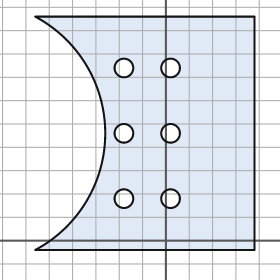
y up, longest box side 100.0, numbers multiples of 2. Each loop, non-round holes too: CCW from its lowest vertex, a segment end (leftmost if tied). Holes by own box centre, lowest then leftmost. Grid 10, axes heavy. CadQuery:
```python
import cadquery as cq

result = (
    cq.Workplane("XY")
    .moveTo(-56.0, -4.0)
    .lineTo(38.0, -4.0)
    .lineTo(38.0, 96.0)
    .lineTo(-56.0, 96.0)
    .threePointArc((-26.0, 46.0), (-56.0, -4.0))
    .close()
    .moveTo(-18.0, 18.0)
    .circle(4.0)
    .moveTo(2.0, 18.0)
    .circle(4.0)
    .moveTo(-18.0, 46.0)
    .circle(4.0)
    .moveTo(2.0, 46.0)
    .circle(4.0)
    .moveTo(-18.0, 74.0)
    .circle(4.0)
    .moveTo(2.0, 74.0)
    .circle(4.0)
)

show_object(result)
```